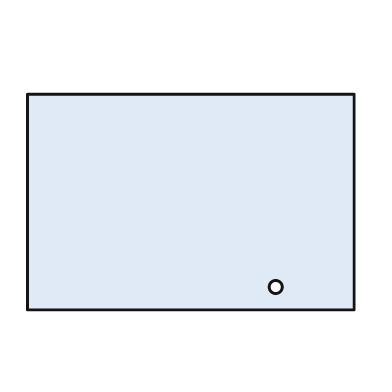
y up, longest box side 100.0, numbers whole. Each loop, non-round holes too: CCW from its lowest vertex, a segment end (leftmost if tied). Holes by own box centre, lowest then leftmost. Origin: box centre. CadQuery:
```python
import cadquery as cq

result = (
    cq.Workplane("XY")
    .moveTo(-50.0, -33.0)
    .lineTo(50.0, -33.0)
    .lineTo(50.0, 33.0)
    .lineTo(-50.0, 33.0)
    .close()
    .moveTo(26.0, -26.0)
    .circle(2.0)
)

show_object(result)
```